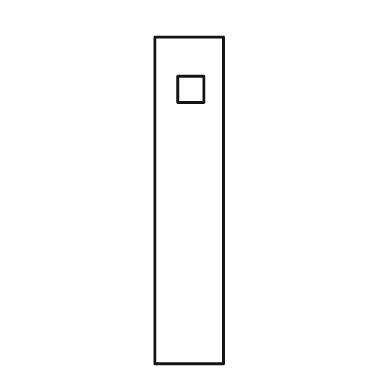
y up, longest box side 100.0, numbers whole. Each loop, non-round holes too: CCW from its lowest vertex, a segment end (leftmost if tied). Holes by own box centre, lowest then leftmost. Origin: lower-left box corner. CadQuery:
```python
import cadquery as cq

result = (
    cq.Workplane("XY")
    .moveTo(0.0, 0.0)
    .lineTo(21.0, 0.0)
    .lineTo(21.0, 100.0)
    .lineTo(0.0, 100.0)
    .close()
    .moveTo(7.0, 80.0)
    .lineTo(15.0, 80.0)
    .lineTo(15.0, 88.0)
    .lineTo(7.0, 88.0)
    .close()
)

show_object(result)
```